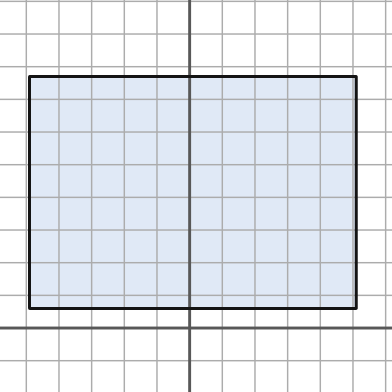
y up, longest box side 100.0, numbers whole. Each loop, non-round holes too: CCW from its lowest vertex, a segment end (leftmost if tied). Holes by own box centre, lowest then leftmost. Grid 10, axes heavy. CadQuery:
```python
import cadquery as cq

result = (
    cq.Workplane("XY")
    .moveTo(-49.0, 6.0)
    .lineTo(51.0, 6.0)
    .lineTo(51.0, 77.0)
    .lineTo(-49.0, 77.0)
    .close()
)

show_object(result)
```